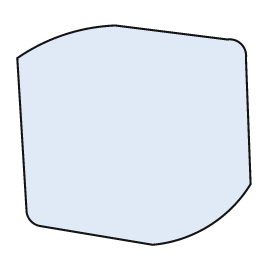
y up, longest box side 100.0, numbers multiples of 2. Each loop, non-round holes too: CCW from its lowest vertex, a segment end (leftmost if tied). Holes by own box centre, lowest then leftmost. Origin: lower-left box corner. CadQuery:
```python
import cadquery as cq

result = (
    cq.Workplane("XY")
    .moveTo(58.0, 0.0)
    .threePointArc((82.0, 8.0), (100.0, 26.0))
    .lineTo(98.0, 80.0)
    .threePointArc((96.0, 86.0), (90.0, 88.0))
    .lineTo(42.0, 94.0)
    .threePointArc((20.0, 90.0), (0.0, 80.0))
    .lineTo(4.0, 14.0)
    .threePointArc((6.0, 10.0), (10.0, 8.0))
    .close()
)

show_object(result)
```